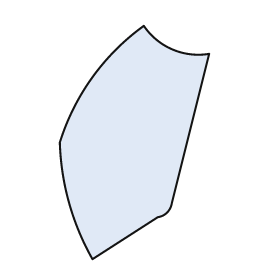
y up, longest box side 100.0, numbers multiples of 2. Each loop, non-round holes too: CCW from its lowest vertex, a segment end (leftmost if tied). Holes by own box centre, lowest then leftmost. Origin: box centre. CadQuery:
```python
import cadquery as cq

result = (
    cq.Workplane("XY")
    .moveTo(-18.0, -50.0)
    .lineTo(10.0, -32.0)
    .threePointArc((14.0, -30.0), (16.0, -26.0))
    .lineTo(32.0, 38.0)
    .threePointArc((16.0, 40.0), (4.0, 50.0))
    .threePointArc((-18.0, 28.0), (-32.0, 0.0))
    .threePointArc((-28.0, -26.0), (-18.0, -50.0))
    .close()
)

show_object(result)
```